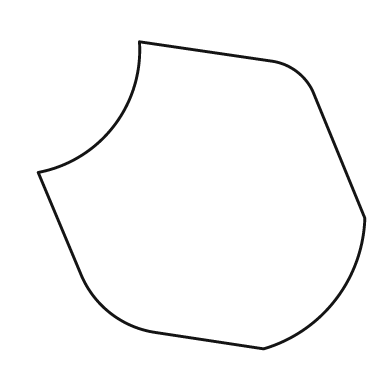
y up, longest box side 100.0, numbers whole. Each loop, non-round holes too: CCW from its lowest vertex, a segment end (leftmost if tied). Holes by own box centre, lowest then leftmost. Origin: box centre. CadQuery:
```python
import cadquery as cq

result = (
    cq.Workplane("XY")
    .moveTo(19.0, -47.0)
    .threePointArc((41.0, -32.0), (50.0, -7.0))
    .lineTo(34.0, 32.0)
    .threePointArc((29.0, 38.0), (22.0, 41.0))
    .lineTo(-19.0, 47.0)
    .threePointArc((-27.0, 21.0), (-50.0, 7.0))
    .lineTo(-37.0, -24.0)
    .threePointArc((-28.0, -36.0), (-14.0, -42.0))
    .close()
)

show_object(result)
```